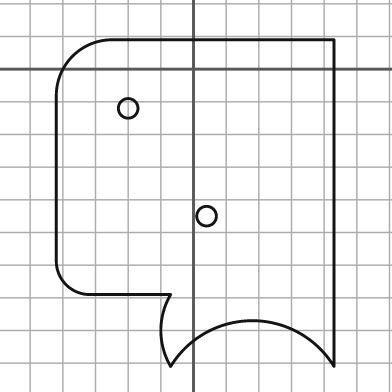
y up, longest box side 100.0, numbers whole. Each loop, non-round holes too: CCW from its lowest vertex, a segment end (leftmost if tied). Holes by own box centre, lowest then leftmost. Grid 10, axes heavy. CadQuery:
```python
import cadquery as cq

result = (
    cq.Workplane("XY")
    .moveTo(-7.0, -91.0)
    .threePointArc((18.0, -77.0), (43.0, -91.0))
    .lineTo(43.0, 9.0)
    .lineTo(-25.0, 9.0)
    .threePointArc((-37.0, 4.0), (-42.0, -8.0))
    .lineTo(-42.0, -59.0)
    .threePointArc((-39.0, -66.0), (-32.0, -69.0))
    .lineTo(-7.0, -69.0)
    .threePointArc((-10.0, -80.0), (-7.0, -91.0))
    .close()
    .moveTo(4.0, -45.0)
    .circle(3.0)
    .moveTo(-20.0, -12.0)
    .circle(3.0)
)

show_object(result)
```